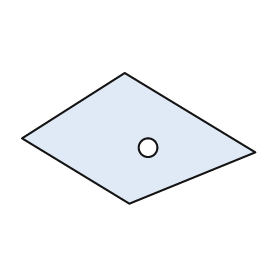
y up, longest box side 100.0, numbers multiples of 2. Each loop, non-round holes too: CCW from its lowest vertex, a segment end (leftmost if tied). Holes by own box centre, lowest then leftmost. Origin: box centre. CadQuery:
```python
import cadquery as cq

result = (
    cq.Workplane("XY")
    .moveTo(-4.0, -28.0)
    .lineTo(50.0, -6.0)
    .lineTo(-6.0, 28.0)
    .lineTo(-50.0, 0.0)
    .close()
    .moveTo(4.0, -4.0)
    .circle(4.0)
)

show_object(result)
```